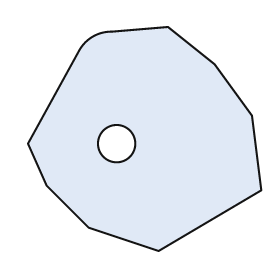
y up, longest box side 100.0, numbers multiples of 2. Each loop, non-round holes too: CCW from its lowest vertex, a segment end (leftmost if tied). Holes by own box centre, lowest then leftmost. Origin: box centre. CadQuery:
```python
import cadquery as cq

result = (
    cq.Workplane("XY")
    .moveTo(6.0, -48.0)
    .lineTo(50.0, -22.0)
    .lineTo(46.0, 10.0)
    .lineTo(30.0, 32.0)
    .lineTo(10.0, 48.0)
    .lineTo(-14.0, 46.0)
    .threePointArc((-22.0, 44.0), (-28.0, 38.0))
    .lineTo(-50.0, -2.0)
    .lineTo(-42.0, -20.0)
    .lineTo(-24.0, -38.0)
    .close()
    .moveTo(-12.0, -2.0)
    .circle(8.0)
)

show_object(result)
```